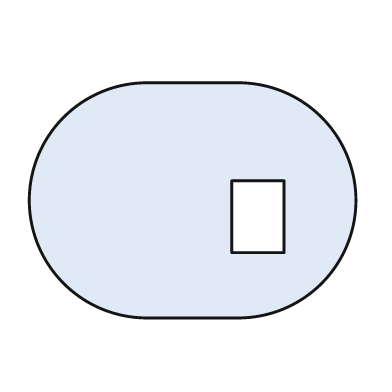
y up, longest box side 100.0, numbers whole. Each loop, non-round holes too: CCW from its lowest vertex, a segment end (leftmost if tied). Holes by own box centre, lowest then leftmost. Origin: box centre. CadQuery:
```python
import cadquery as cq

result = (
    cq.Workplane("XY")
    .moveTo(-14.0, -36.0)
    .lineTo(14.0, -36.0)
    .threePointArc((50.0, 0.0), (14.0, 36.0))
    .lineTo(-14.0, 36.0)
    .threePointArc((-50.0, 0.0), (-14.0, -36.0))
    .close()
    .moveTo(12.0, -16.0)
    .lineTo(28.0, -16.0)
    .lineTo(28.0, 6.0)
    .lineTo(12.0, 6.0)
    .close()
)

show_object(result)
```